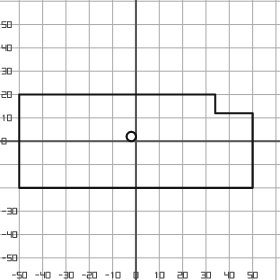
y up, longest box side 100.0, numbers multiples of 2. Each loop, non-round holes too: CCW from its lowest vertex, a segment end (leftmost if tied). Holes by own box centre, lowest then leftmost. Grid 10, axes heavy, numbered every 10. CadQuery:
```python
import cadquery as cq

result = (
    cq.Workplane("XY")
    .moveTo(-50.0, -20.0)
    .lineTo(50.0, -20.0)
    .lineTo(50.0, 12.0)
    .lineTo(34.0, 12.0)
    .lineTo(34.0, 20.0)
    .lineTo(-50.0, 20.0)
    .close()
    .moveTo(-2.0, 2.0)
    .circle(2.0)
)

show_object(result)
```